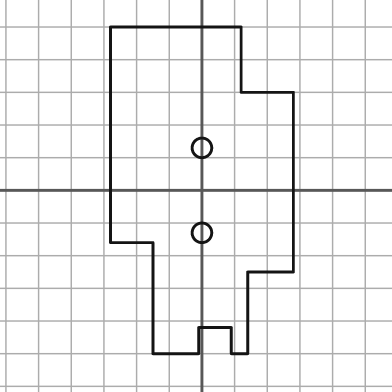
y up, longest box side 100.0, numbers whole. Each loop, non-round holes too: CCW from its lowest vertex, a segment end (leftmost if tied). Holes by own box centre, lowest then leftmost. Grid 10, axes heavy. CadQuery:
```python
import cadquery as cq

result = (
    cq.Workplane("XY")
    .moveTo(-15.0, -50.0)
    .lineTo(-1.0, -50.0)
    .lineTo(-1.0, -42.0)
    .lineTo(9.0, -42.0)
    .lineTo(9.0, -50.0)
    .lineTo(14.0, -50.0)
    .lineTo(14.0, -25.0)
    .lineTo(28.0, -25.0)
    .lineTo(28.0, 30.0)
    .lineTo(12.0, 30.0)
    .lineTo(12.0, 50.0)
    .lineTo(-28.0, 50.0)
    .lineTo(-28.0, -16.0)
    .lineTo(-15.0, -16.0)
    .close()
    .moveTo(0.0, -13.0)
    .circle(3.0)
    .moveTo(0.0, 13.0)
    .circle(3.0)
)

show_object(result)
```